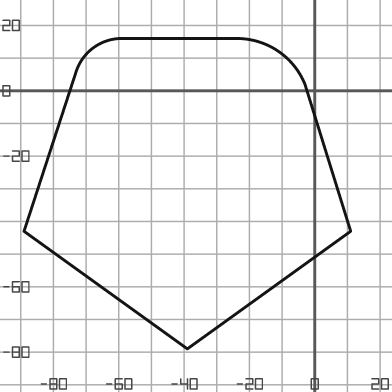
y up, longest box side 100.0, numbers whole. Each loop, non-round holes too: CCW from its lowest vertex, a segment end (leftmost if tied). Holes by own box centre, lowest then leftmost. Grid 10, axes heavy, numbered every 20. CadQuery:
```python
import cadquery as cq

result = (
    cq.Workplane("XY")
    .moveTo(-39.0, -79.0)
    .lineTo(11.0, -43.0)
    .lineTo(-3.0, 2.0)
    .threePointArc((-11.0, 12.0), (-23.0, 16.0))
    .lineTo(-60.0, 16.0)
    .threePointArc((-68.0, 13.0), (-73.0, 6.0))
    .lineTo(-89.0, -43.0)
    .close()
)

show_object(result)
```